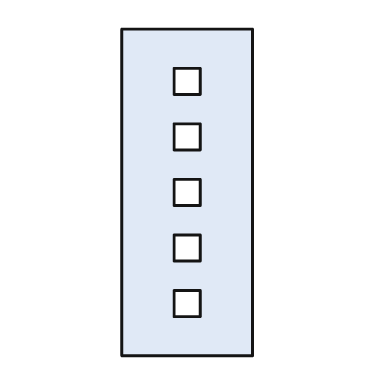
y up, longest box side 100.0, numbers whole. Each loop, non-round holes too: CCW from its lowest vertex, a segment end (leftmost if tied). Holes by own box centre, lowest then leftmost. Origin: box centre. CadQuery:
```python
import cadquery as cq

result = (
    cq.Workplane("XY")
    .moveTo(-20.0, -50.0)
    .lineTo(20.0, -50.0)
    .lineTo(20.0, 50.0)
    .lineTo(-20.0, 50.0)
    .close()
    .moveTo(-4.0, -38.0)
    .lineTo(4.0, -38.0)
    .lineTo(4.0, -30.0)
    .lineTo(-4.0, -30.0)
    .close()
    .moveTo(-4.0, -21.0)
    .lineTo(4.0, -21.0)
    .lineTo(4.0, -13.0)
    .lineTo(-4.0, -13.0)
    .close()
    .moveTo(-4.0, -4.0)
    .lineTo(4.0, -4.0)
    .lineTo(4.0, 4.0)
    .lineTo(-4.0, 4.0)
    .close()
    .moveTo(-4.0, 13.0)
    .lineTo(4.0, 13.0)
    .lineTo(4.0, 21.0)
    .lineTo(-4.0, 21.0)
    .close()
    .moveTo(-4.0, 30.0)
    .lineTo(4.0, 30.0)
    .lineTo(4.0, 38.0)
    .lineTo(-4.0, 38.0)
    .close()
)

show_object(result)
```